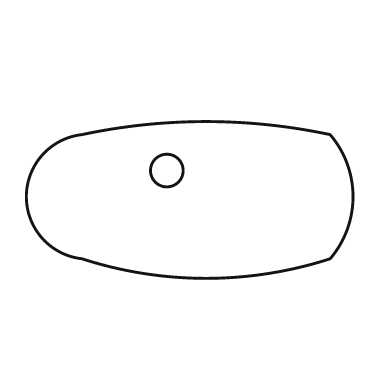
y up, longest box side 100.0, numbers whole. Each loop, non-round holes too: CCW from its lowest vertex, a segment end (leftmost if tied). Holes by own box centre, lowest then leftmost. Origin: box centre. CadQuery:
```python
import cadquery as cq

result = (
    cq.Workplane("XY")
    .moveTo(-33.0, -18.0)
    .threePointArc((5.0, -24.0), (43.0, -18.0))
    .threePointArc((50.0, 1.0), (43.0, 20.0))
    .threePointArc((5.0, 24.0), (-33.0, 20.0))
    .threePointArc((-50.0, 1.0), (-33.0, -18.0))
    .close()
    .moveTo(-7.0, 9.0)
    .circle(5.0)
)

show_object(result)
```